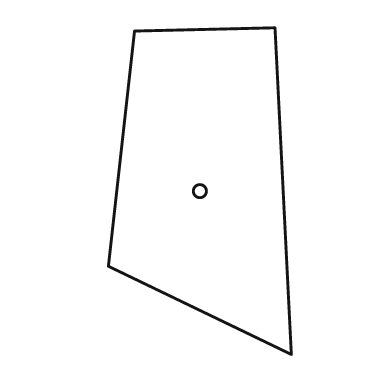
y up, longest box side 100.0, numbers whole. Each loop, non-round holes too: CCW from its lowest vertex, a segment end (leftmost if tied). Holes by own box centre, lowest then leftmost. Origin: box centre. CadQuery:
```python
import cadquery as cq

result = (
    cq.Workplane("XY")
    .moveTo(28.0, -50.0)
    .lineTo(23.0, 50.0)
    .lineTo(-20.0, 49.0)
    .lineTo(-28.0, -23.0)
    .close()
    .moveTo(0.0, 0.0)
    .circle(2.0)
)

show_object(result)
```